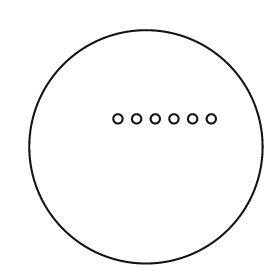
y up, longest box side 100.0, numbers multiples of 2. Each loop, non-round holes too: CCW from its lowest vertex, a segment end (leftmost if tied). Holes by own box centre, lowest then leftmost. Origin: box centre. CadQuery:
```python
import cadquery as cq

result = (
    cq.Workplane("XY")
    .moveTo(0.0, 0.0)
    .circle(50.0)
    .moveTo(-12.0, 12.0)
    .circle(2.0)
    .moveTo(-4.0, 12.0)
    .circle(2.0)
    .moveTo(4.0, 12.0)
    .circle(2.0)
    .moveTo(12.0, 12.0)
    .circle(2.0)
    .moveTo(20.0, 12.0)
    .circle(2.0)
    .moveTo(28.0, 12.0)
    .circle(2.0)
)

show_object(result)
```